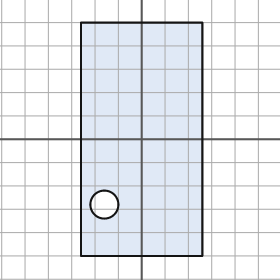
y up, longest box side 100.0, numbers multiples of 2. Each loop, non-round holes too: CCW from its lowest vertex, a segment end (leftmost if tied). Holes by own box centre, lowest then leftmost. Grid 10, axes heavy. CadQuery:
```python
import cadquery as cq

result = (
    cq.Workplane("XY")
    .moveTo(-26.0, -50.0)
    .lineTo(26.0, -50.0)
    .lineTo(26.0, 50.0)
    .lineTo(-26.0, 50.0)
    .close()
    .moveTo(-16.0, -28.0)
    .circle(6.0)
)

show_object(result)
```